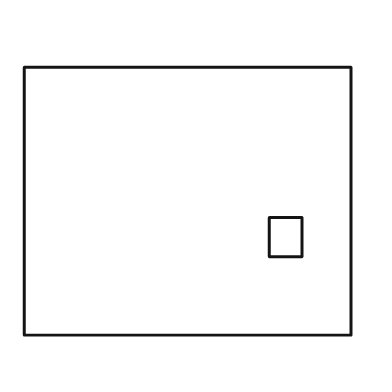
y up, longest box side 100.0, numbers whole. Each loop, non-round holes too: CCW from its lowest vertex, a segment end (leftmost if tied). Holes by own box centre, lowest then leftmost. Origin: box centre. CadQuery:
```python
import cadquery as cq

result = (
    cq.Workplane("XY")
    .moveTo(-50.0, -41.0)
    .lineTo(50.0, -41.0)
    .lineTo(50.0, 41.0)
    .lineTo(-50.0, 41.0)
    .close()
    .moveTo(25.0, -17.0)
    .lineTo(35.0, -17.0)
    .lineTo(35.0, -5.0)
    .lineTo(25.0, -5.0)
    .close()
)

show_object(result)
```